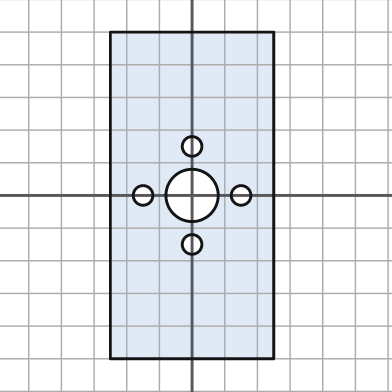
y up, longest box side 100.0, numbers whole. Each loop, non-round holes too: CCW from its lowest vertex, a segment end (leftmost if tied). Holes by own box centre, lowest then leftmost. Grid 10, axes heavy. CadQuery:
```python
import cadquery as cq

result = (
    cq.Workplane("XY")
    .moveTo(-25.0, -50.0)
    .lineTo(25.0, -50.0)
    .lineTo(25.0, 50.0)
    .lineTo(-25.0, 50.0)
    .close()
    .moveTo(0.0, -15.0)
    .circle(3.0)
    .moveTo(-15.0, 0.0)
    .circle(3.0)
    .moveTo(0.0, 0.0)
    .circle(8.0)
    .moveTo(15.0, 0.0)
    .circle(3.0)
    .moveTo(0.0, 15.0)
    .circle(3.0)
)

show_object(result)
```